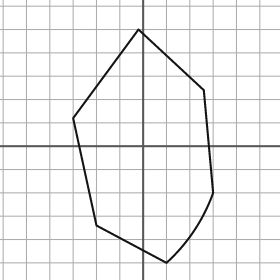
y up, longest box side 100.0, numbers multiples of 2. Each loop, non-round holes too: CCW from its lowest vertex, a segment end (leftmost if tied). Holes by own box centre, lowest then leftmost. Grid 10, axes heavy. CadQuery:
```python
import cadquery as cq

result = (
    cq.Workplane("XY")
    .moveTo(10.0, -50.0)
    .threePointArc((22.0, -36.0), (30.0, -20.0))
    .lineTo(26.0, 24.0)
    .lineTo(-2.0, 50.0)
    .lineTo(-30.0, 12.0)
    .lineTo(-20.0, -34.0)
    .close()
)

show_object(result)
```